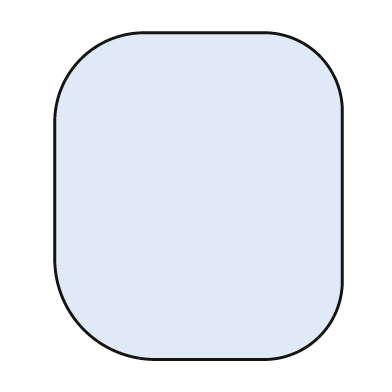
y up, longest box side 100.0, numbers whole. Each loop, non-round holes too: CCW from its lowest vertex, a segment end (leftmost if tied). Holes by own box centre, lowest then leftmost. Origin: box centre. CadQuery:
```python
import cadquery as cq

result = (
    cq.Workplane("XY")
    .moveTo(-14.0, -50.0)
    .lineTo(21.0, -50.0)
    .threePointArc((37.0, -43.0), (44.0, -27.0))
    .lineTo(44.0, 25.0)
    .threePointArc((37.0, 43.0), (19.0, 50.0))
    .lineTo(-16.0, 50.0)
    .threePointArc((-36.0, 42.0), (-44.0, 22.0))
    .lineTo(-44.0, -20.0)
    .threePointArc((-35.0, -41.0), (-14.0, -50.0))
    .close()
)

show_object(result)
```